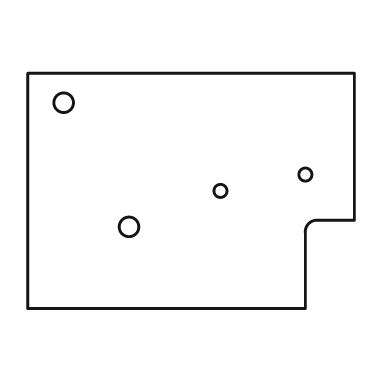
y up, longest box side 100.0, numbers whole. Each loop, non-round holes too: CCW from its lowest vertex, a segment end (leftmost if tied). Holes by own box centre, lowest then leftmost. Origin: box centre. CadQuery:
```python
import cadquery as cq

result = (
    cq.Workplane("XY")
    .moveTo(-50.0, -36.0)
    .lineTo(35.0, -36.0)
    .lineTo(35.0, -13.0)
    .threePointArc((36.0, -10.0), (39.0, -9.0))
    .lineTo(50.0, -9.0)
    .lineTo(50.0, 36.0)
    .lineTo(-50.0, 36.0)
    .close()
    .moveTo(-19.0, -11.0)
    .circle(3.0)
    .moveTo(9.0, 0.0)
    .circle(2.0)
    .moveTo(35.0, 5.0)
    .circle(2.0)
    .moveTo(-39.0, 27.0)
    .circle(3.0)
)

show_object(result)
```